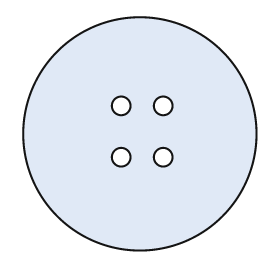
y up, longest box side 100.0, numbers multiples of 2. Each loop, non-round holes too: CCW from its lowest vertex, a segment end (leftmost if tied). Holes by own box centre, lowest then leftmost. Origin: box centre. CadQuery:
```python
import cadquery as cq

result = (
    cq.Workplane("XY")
    .moveTo(0.0, 0.0)
    .circle(50.0)
    .moveTo(-8.0, -10.0)
    .circle(4.0)
    .moveTo(10.0, -10.0)
    .circle(4.0)
    .moveTo(-8.0, 12.0)
    .circle(4.0)
    .moveTo(10.0, 12.0)
    .circle(4.0)
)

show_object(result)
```